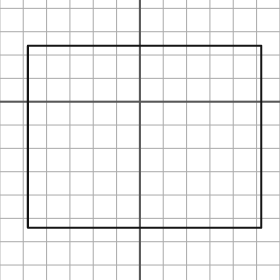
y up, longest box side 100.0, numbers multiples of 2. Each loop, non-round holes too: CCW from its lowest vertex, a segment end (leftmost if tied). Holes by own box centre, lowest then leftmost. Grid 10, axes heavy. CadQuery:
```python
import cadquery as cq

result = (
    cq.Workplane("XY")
    .moveTo(-48.0, -54.0)
    .lineTo(52.0, -54.0)
    .lineTo(52.0, 24.0)
    .lineTo(-48.0, 24.0)
    .close()
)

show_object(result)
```